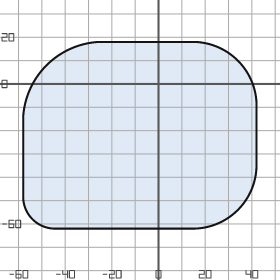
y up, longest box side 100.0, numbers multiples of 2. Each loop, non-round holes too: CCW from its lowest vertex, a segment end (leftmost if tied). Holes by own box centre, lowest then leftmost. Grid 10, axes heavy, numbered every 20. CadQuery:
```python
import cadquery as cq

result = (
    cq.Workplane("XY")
    .moveTo(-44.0, -62.0)
    .lineTo(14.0, -62.0)
    .threePointArc((34.0, -54.0), (42.0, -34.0))
    .lineTo(42.0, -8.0)
    .threePointArc((34.0, 10.0), (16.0, 18.0))
    .lineTo(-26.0, 18.0)
    .threePointArc((-48.0, 8.0), (-58.0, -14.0))
    .lineTo(-58.0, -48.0)
    .threePointArc((-54.0, -58.0), (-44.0, -62.0))
    .close()
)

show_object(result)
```